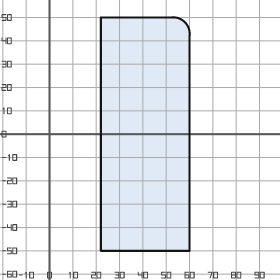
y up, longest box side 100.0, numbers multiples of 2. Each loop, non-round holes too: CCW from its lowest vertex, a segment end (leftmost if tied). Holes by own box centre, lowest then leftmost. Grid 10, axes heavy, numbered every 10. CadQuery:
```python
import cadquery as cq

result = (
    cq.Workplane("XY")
    .moveTo(22.0, -50.0)
    .lineTo(60.0, -50.0)
    .lineTo(60.0, 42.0)
    .threePointArc((58.0, 48.0), (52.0, 50.0))
    .lineTo(22.0, 50.0)
    .close()
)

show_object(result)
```